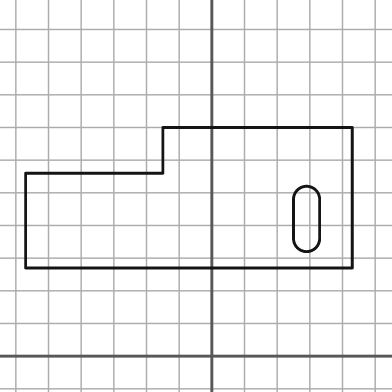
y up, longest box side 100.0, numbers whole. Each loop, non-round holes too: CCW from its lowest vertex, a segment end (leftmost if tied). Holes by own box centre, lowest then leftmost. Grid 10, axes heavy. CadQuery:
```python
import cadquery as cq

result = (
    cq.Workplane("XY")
    .moveTo(-57.0, 27.0)
    .lineTo(43.0, 27.0)
    .lineTo(43.0, 70.0)
    .lineTo(-15.0, 70.0)
    .lineTo(-15.0, 56.0)
    .lineTo(-57.0, 56.0)
    .close()
    .moveTo(25.0, 36.0)
    .threePointArc((29.0, 32.0), (33.0, 36.0))
    .lineTo(33.0, 48.0)
    .threePointArc((29.0, 52.0), (25.0, 48.0))
    .close()
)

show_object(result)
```